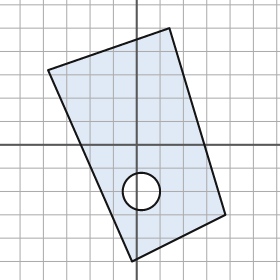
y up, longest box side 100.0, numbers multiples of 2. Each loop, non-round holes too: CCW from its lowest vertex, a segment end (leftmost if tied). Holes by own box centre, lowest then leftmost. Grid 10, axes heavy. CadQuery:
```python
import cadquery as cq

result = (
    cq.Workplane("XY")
    .moveTo(-2.0, -50.0)
    .lineTo(38.0, -30.0)
    .lineTo(14.0, 50.0)
    .lineTo(-38.0, 32.0)
    .close()
    .moveTo(2.0, -20.0)
    .circle(8.0)
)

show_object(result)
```